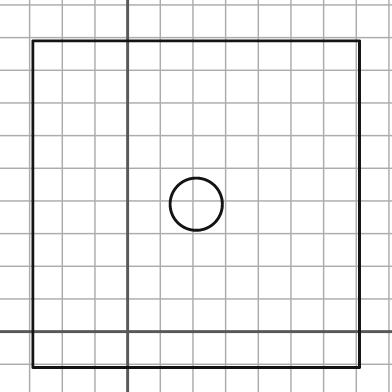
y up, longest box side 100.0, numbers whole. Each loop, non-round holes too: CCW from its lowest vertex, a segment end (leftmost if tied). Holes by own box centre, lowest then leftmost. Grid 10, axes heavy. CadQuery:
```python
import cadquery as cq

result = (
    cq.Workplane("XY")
    .moveTo(-29.0, -11.0)
    .lineTo(71.0, -11.0)
    .lineTo(71.0, 89.0)
    .lineTo(-29.0, 89.0)
    .close()
    .moveTo(21.0, 39.0)
    .circle(8.0)
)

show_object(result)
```